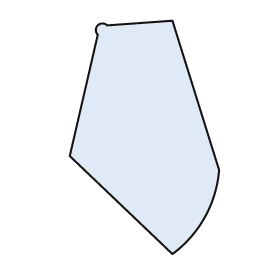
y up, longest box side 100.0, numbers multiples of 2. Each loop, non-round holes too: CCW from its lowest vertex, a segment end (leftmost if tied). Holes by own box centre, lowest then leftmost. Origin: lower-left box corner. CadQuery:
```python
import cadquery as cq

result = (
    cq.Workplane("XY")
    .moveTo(44.0, 0.0)
    .threePointArc((58.0, 16.0), (64.0, 36.0))
    .lineTo(44.0, 100.0)
    .lineTo(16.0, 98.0)
    .threePointArc((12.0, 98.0), (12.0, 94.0))
    .lineTo(0.0, 42.0)
    .close()
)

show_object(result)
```